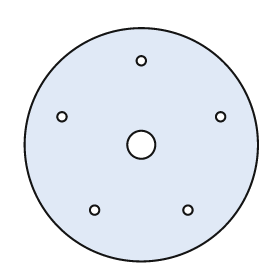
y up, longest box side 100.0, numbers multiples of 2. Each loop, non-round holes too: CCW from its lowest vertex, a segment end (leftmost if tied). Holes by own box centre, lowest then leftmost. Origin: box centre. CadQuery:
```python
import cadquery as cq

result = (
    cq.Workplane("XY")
    .moveTo(0.0, 0.0)
    .circle(50.0)
    .moveTo(-20.0, -28.0)
    .circle(2.0)
    .moveTo(20.0, -28.0)
    .circle(2.0)
    .moveTo(0.0, 0.0)
    .circle(6.0)
    .moveTo(-34.0, 12.0)
    .circle(2.0)
    .moveTo(34.0, 12.0)
    .circle(2.0)
    .moveTo(0.0, 36.0)
    .circle(2.0)
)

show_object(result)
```